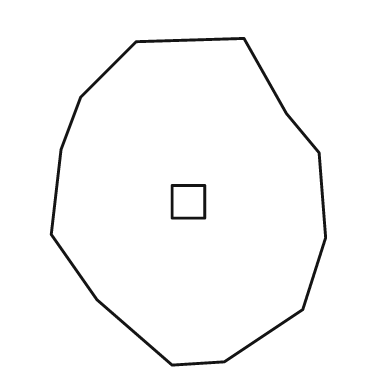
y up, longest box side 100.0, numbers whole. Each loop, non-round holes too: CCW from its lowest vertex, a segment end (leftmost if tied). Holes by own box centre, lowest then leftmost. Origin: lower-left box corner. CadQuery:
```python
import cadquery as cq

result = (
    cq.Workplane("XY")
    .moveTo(37.0, 0.0)
    .lineTo(53.0, 1.0)
    .lineTo(77.0, 17.0)
    .lineTo(84.0, 39.0)
    .lineTo(82.0, 65.0)
    .lineTo(72.0, 77.0)
    .lineTo(59.0, 100.0)
    .lineTo(26.0, 99.0)
    .lineTo(9.0, 82.0)
    .lineTo(3.0, 66.0)
    .lineTo(0.0, 40.0)
    .lineTo(14.0, 20.0)
    .close()
    .moveTo(37.0, 45.0)
    .lineTo(47.0, 45.0)
    .lineTo(47.0, 55.0)
    .lineTo(37.0, 55.0)
    .close()
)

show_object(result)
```